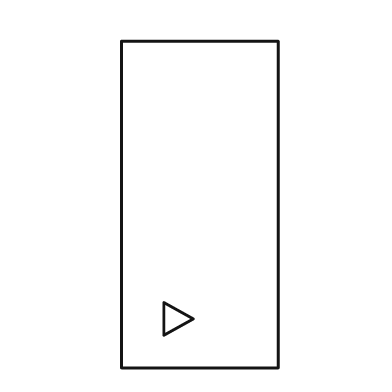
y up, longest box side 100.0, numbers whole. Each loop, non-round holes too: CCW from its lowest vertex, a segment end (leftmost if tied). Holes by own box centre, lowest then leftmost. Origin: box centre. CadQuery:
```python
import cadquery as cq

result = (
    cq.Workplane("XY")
    .moveTo(-24.0, -50.0)
    .lineTo(24.0, -50.0)
    .lineTo(24.0, 50.0)
    .lineTo(-24.0, 50.0)
    .close()
    .moveTo(-11.0, -40.0)
    .lineTo(-2.0, -35.0)
    .lineTo(-11.0, -30.0)
    .close()
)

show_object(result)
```